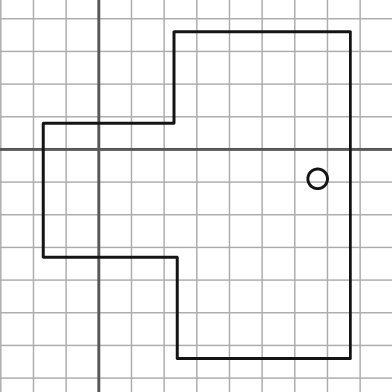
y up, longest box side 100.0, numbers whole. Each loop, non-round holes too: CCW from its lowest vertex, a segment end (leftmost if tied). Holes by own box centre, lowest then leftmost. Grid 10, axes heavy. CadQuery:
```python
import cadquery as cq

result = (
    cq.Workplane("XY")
    .moveTo(24.0, -64.0)
    .lineTo(77.0, -64.0)
    .lineTo(77.0, 36.0)
    .lineTo(23.0, 36.0)
    .lineTo(23.0, 8.0)
    .lineTo(-17.0, 8.0)
    .lineTo(-17.0, -33.0)
    .lineTo(24.0, -33.0)
    .close()
    .moveTo(67.0, -9.0)
    .circle(3.0)
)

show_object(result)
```